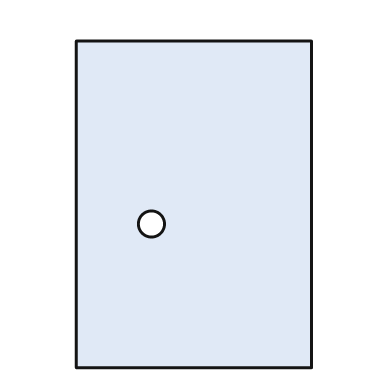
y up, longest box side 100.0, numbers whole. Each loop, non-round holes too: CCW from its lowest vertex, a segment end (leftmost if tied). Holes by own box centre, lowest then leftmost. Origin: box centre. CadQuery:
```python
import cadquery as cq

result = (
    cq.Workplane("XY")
    .moveTo(-36.0, -50.0)
    .lineTo(36.0, -50.0)
    .lineTo(36.0, 50.0)
    .lineTo(-36.0, 50.0)
    .close()
    .moveTo(-13.0, -6.0)
    .circle(4.0)
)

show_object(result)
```